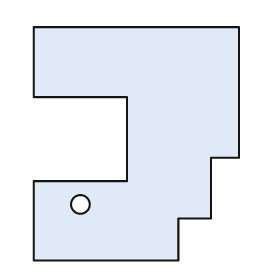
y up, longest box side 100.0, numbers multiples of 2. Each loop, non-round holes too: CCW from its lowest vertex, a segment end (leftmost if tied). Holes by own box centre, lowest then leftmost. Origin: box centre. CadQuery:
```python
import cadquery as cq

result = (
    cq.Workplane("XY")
    .moveTo(-44.0, -50.0)
    .lineTo(18.0, -50.0)
    .lineTo(18.0, -32.0)
    .lineTo(32.0, -32.0)
    .lineTo(32.0, -6.0)
    .lineTo(44.0, -6.0)
    .lineTo(44.0, 50.0)
    .lineTo(-44.0, 50.0)
    .lineTo(-44.0, 20.0)
    .lineTo(-4.0, 20.0)
    .lineTo(-4.0, -16.0)
    .lineTo(-44.0, -16.0)
    .close()
    .moveTo(-24.0, -26.0)
    .circle(4.0)
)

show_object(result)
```